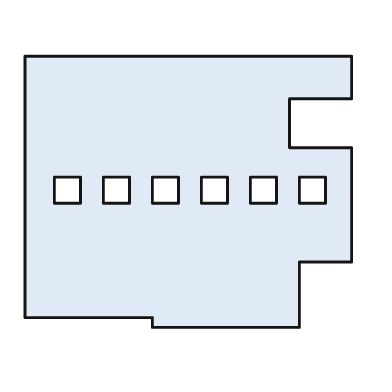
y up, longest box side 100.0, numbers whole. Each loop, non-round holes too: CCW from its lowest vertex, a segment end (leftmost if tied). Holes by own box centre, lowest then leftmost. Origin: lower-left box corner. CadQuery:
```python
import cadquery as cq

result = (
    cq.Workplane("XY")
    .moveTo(39.0, 0.0)
    .lineTo(84.0, 0.0)
    .lineTo(84.0, 20.0)
    .lineTo(100.0, 20.0)
    .lineTo(100.0, 55.0)
    .lineTo(81.0, 55.0)
    .lineTo(81.0, 70.0)
    .lineTo(100.0, 70.0)
    .lineTo(100.0, 83.0)
    .lineTo(0.0, 83.0)
    .lineTo(0.0, 3.0)
    .lineTo(39.0, 3.0)
    .close()
    .moveTo(9.0, 38.0)
    .lineTo(17.0, 38.0)
    .lineTo(17.0, 46.0)
    .lineTo(9.0, 46.0)
    .close()
    .moveTo(24.0, 38.0)
    .lineTo(32.0, 38.0)
    .lineTo(32.0, 46.0)
    .lineTo(24.0, 46.0)
    .close()
    .moveTo(39.0, 38.0)
    .lineTo(47.0, 38.0)
    .lineTo(47.0, 46.0)
    .lineTo(39.0, 46.0)
    .close()
    .moveTo(54.0, 38.0)
    .lineTo(62.0, 38.0)
    .lineTo(62.0, 46.0)
    .lineTo(54.0, 46.0)
    .close()
    .moveTo(69.0, 38.0)
    .lineTo(77.0, 38.0)
    .lineTo(77.0, 46.0)
    .lineTo(69.0, 46.0)
    .close()
    .moveTo(84.0, 38.0)
    .lineTo(92.0, 38.0)
    .lineTo(92.0, 46.0)
    .lineTo(84.0, 46.0)
    .close()
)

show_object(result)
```